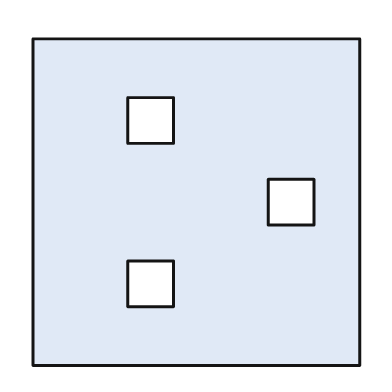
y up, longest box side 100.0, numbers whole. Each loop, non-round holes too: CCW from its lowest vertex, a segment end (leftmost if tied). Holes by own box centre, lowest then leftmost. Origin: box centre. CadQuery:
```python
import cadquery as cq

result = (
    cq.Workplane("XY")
    .moveTo(-50.0, -50.0)
    .lineTo(50.0, -50.0)
    .lineTo(50.0, 50.0)
    .lineTo(-50.0, 50.0)
    .close()
    .moveTo(-21.0, -32.0)
    .lineTo(-7.0, -32.0)
    .lineTo(-7.0, -18.0)
    .lineTo(-21.0, -18.0)
    .close()
    .moveTo(22.0, -7.0)
    .lineTo(36.0, -7.0)
    .lineTo(36.0, 7.0)
    .lineTo(22.0, 7.0)
    .close()
    .moveTo(-21.0, 18.0)
    .lineTo(-7.0, 18.0)
    .lineTo(-7.0, 32.0)
    .lineTo(-21.0, 32.0)
    .close()
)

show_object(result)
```